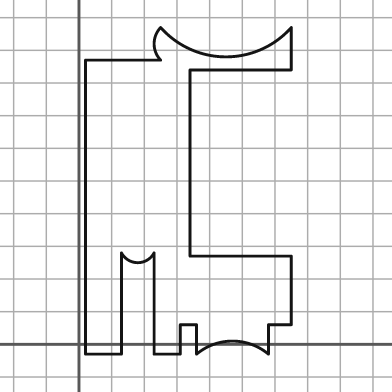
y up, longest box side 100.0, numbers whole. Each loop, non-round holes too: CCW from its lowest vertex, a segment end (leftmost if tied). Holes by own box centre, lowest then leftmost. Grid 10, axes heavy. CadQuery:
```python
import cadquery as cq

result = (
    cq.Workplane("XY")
    .moveTo(2.0, -3.0)
    .lineTo(13.0, -3.0)
    .lineTo(13.0, 28.0)
    .threePointArc((18.0, 25.0), (23.0, 28.0))
    .lineTo(23.0, -3.0)
    .lineTo(31.0, -3.0)
    .lineTo(31.0, 6.0)
    .lineTo(36.0, 6.0)
    .lineTo(36.0, -3.0)
    .threePointArc((47.0, 1.0), (58.0, -3.0))
    .lineTo(58.0, 6.0)
    .lineTo(65.0, 6.0)
    .lineTo(65.0, 27.0)
    .lineTo(34.0, 27.0)
    .lineTo(34.0, 84.0)
    .lineTo(65.0, 84.0)
    .lineTo(65.0, 97.0)
    .threePointArc((45.0, 88.0), (25.0, 97.0))
    .threePointArc((23.0, 92.0), (25.0, 87.0))
    .lineTo(2.0, 87.0)
    .close()
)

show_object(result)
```